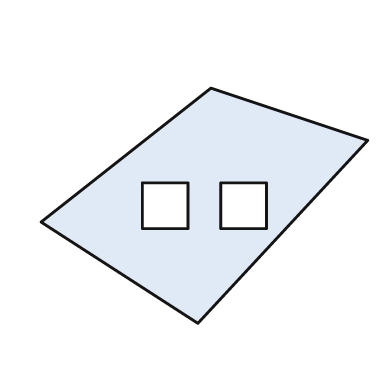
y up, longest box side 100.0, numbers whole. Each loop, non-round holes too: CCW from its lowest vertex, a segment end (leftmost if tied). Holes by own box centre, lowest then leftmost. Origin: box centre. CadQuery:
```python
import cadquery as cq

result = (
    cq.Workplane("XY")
    .moveTo(-2.0, -36.0)
    .lineTo(50.0, 20.0)
    .lineTo(2.0, 36.0)
    .lineTo(-50.0, -5.0)
    .close()
    .moveTo(-19.0, -7.0)
    .lineTo(-5.0, -7.0)
    .lineTo(-5.0, 7.0)
    .lineTo(-19.0, 7.0)
    .close()
    .moveTo(5.0, -7.0)
    .lineTo(19.0, -7.0)
    .lineTo(19.0, 7.0)
    .lineTo(5.0, 7.0)
    .close()
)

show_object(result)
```